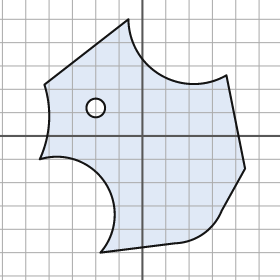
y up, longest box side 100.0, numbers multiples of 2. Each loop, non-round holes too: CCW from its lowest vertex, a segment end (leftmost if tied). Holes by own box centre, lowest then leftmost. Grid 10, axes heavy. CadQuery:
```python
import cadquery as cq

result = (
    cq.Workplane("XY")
    .moveTo(-18.0, -50.0)
    .lineTo(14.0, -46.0)
    .threePointArc((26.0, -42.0), (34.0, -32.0))
    .lineTo(44.0, -14.0)
    .lineTo(36.0, 26.0)
    .threePointArc((8.0, 26.0), (-6.0, 50.0))
    .lineTo(-42.0, 22.0)
    .threePointArc((-40.0, 6.0), (-44.0, -10.0))
    .threePointArc((-16.0, -20.0), (-18.0, -50.0))
    .close()
    .moveTo(-20.0, 12.0)
    .circle(4.0)
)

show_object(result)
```